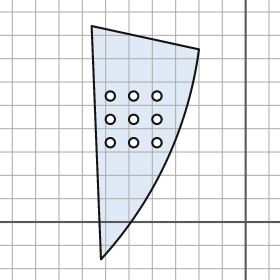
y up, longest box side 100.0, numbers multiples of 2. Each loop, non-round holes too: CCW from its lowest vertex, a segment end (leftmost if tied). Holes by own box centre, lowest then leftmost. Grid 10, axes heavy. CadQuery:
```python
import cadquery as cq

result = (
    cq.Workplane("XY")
    .moveTo(-62.0, -16.0)
    .threePointArc((-34.0, 26.0), (-20.0, 74.0))
    .lineTo(-66.0, 84.0)
    .close()
    .moveTo(-58.0, 34.0)
    .circle(2.0)
    .moveTo(-48.0, 34.0)
    .circle(2.0)
    .moveTo(-38.0, 34.0)
    .circle(2.0)
    .moveTo(-58.0, 44.0)
    .circle(2.0)
    .moveTo(-48.0, 44.0)
    .circle(2.0)
    .moveTo(-38.0, 44.0)
    .circle(2.0)
    .moveTo(-58.0, 54.0)
    .circle(2.0)
    .moveTo(-48.0, 54.0)
    .circle(2.0)
    .moveTo(-38.0, 54.0)
    .circle(2.0)
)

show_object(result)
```